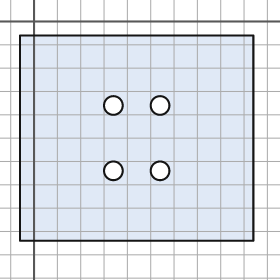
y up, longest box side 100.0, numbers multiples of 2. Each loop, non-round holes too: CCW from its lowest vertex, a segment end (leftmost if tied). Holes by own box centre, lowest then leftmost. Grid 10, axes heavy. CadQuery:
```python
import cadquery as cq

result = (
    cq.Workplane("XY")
    .moveTo(-6.0, -94.0)
    .lineTo(94.0, -94.0)
    .lineTo(94.0, -6.0)
    .lineTo(-6.0, -6.0)
    .close()
    .moveTo(34.0, -64.0)
    .circle(4.0)
    .moveTo(54.0, -64.0)
    .circle(4.0)
    .moveTo(34.0, -36.0)
    .circle(4.0)
    .moveTo(54.0, -36.0)
    .circle(4.0)
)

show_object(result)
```